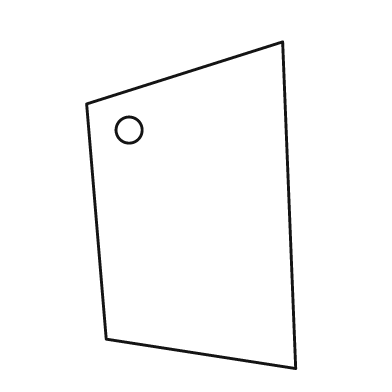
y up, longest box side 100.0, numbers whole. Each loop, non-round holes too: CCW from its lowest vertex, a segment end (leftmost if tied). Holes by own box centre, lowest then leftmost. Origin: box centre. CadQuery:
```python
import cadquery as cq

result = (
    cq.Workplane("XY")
    .moveTo(32.0, -50.0)
    .lineTo(28.0, 50.0)
    .lineTo(-32.0, 31.0)
    .lineTo(-26.0, -41.0)
    .close()
    .moveTo(-19.0, 23.0)
    .circle(4.0)
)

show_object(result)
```